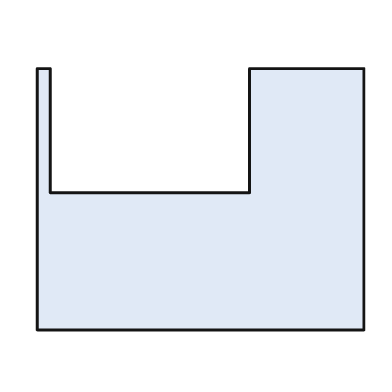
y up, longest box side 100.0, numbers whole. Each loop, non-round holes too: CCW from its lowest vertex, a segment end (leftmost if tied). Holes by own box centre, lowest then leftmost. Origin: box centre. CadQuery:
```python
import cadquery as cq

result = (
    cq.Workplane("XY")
    .moveTo(-50.0, -40.0)
    .lineTo(50.0, -40.0)
    .lineTo(50.0, 40.0)
    .lineTo(15.0, 40.0)
    .lineTo(15.0, 2.0)
    .lineTo(-46.0, 2.0)
    .lineTo(-46.0, 40.0)
    .lineTo(-50.0, 40.0)
    .close()
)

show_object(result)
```